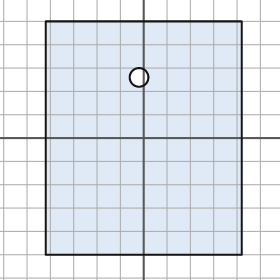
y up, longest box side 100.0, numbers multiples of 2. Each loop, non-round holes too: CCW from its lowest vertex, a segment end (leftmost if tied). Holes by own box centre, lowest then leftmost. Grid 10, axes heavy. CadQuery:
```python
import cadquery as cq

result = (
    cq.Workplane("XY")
    .moveTo(-42.0, -50.0)
    .lineTo(42.0, -50.0)
    .lineTo(42.0, 50.0)
    .lineTo(-42.0, 50.0)
    .close()
    .moveTo(-2.0, 26.0)
    .circle(4.0)
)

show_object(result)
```